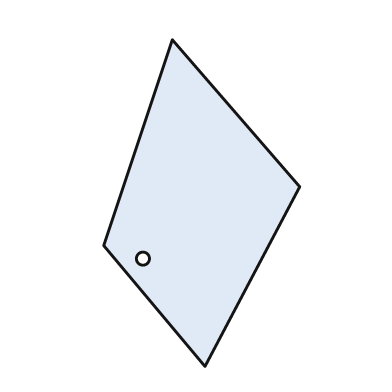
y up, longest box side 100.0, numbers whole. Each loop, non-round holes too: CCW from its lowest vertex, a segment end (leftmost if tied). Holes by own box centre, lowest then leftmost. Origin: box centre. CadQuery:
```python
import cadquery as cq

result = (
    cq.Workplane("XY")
    .moveTo(1.0, -50.0)
    .lineTo(30.0, 5.0)
    .lineTo(-9.0, 50.0)
    .lineTo(-30.0, -13.0)
    .close()
    .moveTo(-18.0, -17.0)
    .circle(2.0)
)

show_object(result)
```